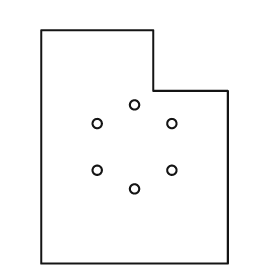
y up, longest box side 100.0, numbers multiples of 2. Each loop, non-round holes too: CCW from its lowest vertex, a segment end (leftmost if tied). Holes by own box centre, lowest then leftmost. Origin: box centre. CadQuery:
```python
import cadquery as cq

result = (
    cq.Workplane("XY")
    .moveTo(-40.0, -50.0)
    .lineTo(40.0, -50.0)
    .lineTo(40.0, 24.0)
    .lineTo(8.0, 24.0)
    .lineTo(8.0, 50.0)
    .lineTo(-40.0, 50.0)
    .close()
    .moveTo(0.0, -18.0)
    .circle(2.0)
    .moveTo(-16.0, -10.0)
    .circle(2.0)
    .moveTo(16.0, -10.0)
    .circle(2.0)
    .moveTo(-16.0, 10.0)
    .circle(2.0)
    .moveTo(16.0, 10.0)
    .circle(2.0)
    .moveTo(0.0, 18.0)
    .circle(2.0)
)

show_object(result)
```